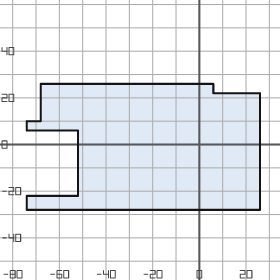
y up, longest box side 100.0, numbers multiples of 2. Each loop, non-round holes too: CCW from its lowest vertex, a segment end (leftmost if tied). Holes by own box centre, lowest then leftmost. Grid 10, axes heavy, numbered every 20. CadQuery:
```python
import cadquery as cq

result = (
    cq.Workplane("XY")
    .moveTo(-74.0, -28.0)
    .lineTo(26.0, -28.0)
    .lineTo(26.0, 22.0)
    .lineTo(6.0, 22.0)
    .lineTo(6.0, 26.0)
    .lineTo(-68.0, 26.0)
    .lineTo(-68.0, 10.0)
    .lineTo(-74.0, 10.0)
    .lineTo(-74.0, 6.0)
    .lineTo(-52.0, 6.0)
    .lineTo(-52.0, -22.0)
    .lineTo(-74.0, -22.0)
    .close()
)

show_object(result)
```